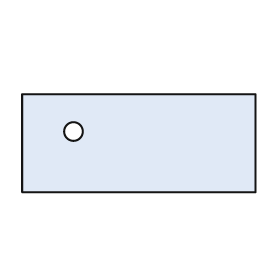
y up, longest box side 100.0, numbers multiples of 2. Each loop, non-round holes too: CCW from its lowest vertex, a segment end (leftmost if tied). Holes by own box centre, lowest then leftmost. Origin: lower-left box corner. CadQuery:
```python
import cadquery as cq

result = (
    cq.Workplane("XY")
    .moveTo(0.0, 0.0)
    .lineTo(100.0, 0.0)
    .lineTo(100.0, 42.0)
    .lineTo(0.0, 42.0)
    .close()
    .moveTo(22.0, 26.0)
    .circle(4.0)
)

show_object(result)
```